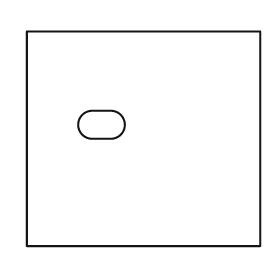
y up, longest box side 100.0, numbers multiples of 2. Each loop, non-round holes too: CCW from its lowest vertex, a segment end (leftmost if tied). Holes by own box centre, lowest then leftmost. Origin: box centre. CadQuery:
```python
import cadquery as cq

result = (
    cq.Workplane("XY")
    .moveTo(-50.0, -46.0)
    .lineTo(50.0, -46.0)
    .lineTo(50.0, 46.0)
    .lineTo(-50.0, 46.0)
    .close()
    .moveTo(-22.0, 0.0)
    .lineTo(-14.0, 0.0)
    .threePointArc((-8.0, 6.0), (-14.0, 12.0))
    .lineTo(-22.0, 12.0)
    .threePointArc((-28.0, 6.0), (-22.0, 0.0))
    .close()
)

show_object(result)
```